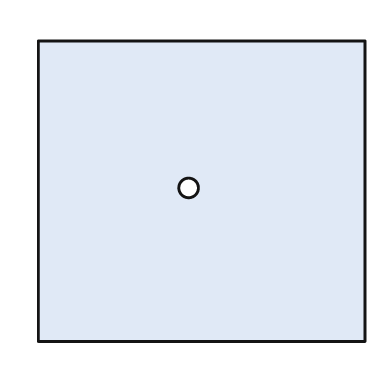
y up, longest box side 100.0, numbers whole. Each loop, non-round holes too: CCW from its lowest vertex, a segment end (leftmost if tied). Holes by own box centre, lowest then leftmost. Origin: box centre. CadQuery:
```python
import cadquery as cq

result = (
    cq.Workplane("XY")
    .moveTo(-50.0, -46.0)
    .lineTo(50.0, -46.0)
    .lineTo(50.0, 46.0)
    .lineTo(-50.0, 46.0)
    .close()
    .moveTo(-4.0, 1.0)
    .circle(3.0)
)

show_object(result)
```